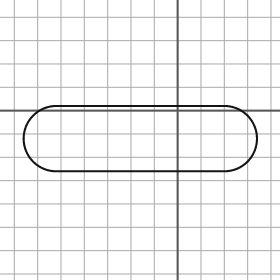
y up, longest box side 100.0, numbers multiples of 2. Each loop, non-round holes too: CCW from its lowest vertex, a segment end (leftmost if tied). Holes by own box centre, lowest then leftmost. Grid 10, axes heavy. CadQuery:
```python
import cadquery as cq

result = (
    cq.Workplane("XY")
    .moveTo(-52.0, -26.0)
    .lineTo(20.0, -26.0)
    .threePointArc((34.0, -12.0), (20.0, 2.0))
    .lineTo(-52.0, 2.0)
    .threePointArc((-66.0, -12.0), (-52.0, -26.0))
    .close()
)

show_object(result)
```